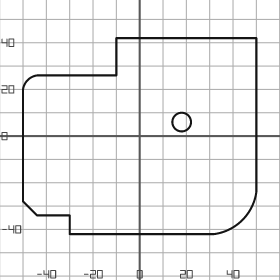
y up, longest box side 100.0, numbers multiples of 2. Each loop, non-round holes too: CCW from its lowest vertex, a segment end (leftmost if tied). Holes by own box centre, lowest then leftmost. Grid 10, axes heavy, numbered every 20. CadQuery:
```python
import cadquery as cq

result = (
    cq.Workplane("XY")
    .moveTo(-30.0, -42.0)
    .lineTo(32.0, -42.0)
    .threePointArc((44.0, -36.0), (50.0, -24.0))
    .lineTo(50.0, 42.0)
    .lineTo(-10.0, 42.0)
    .lineTo(-10.0, 26.0)
    .lineTo(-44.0, 26.0)
    .threePointArc((-48.0, 24.0), (-50.0, 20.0))
    .lineTo(-50.0, -28.0)
    .lineTo(-44.0, -34.0)
    .lineTo(-30.0, -34.0)
    .close()
    .moveTo(18.0, 6.0)
    .circle(4.0)
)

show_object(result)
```